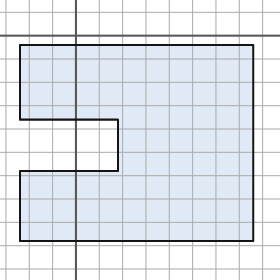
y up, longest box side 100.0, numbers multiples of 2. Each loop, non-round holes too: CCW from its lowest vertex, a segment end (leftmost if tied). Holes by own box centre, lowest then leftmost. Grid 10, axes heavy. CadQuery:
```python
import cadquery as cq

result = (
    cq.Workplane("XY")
    .moveTo(-24.0, -88.0)
    .lineTo(76.0, -88.0)
    .lineTo(76.0, -4.0)
    .lineTo(-24.0, -4.0)
    .lineTo(-24.0, -36.0)
    .lineTo(18.0, -36.0)
    .lineTo(18.0, -58.0)
    .lineTo(-24.0, -58.0)
    .close()
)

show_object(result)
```